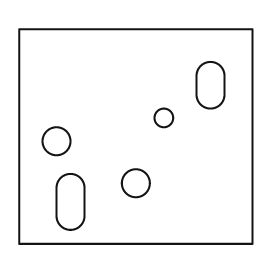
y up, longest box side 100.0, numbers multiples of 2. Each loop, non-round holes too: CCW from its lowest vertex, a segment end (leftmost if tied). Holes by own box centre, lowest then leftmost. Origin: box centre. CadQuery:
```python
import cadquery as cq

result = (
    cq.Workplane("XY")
    .moveTo(-50.0, -46.0)
    .lineTo(50.0, -46.0)
    .lineTo(50.0, 46.0)
    .lineTo(-50.0, 46.0)
    .close()
    .moveTo(-34.0, -34.0)
    .threePointArc((-28.0, -40.0), (-22.0, -34.0))
    .lineTo(-22.0, -22.0)
    .threePointArc((-28.0, -16.0), (-34.0, -22.0))
    .close()
    .moveTo(0.0, -20.0)
    .circle(6.0)
    .moveTo(-34.0, -2.0)
    .circle(6.0)
    .moveTo(12.0, 8.0)
    .circle(4.0)
    .moveTo(26.0, 18.0)
    .threePointArc((32.0, 12.0), (38.0, 18.0))
    .lineTo(38.0, 26.0)
    .threePointArc((32.0, 32.0), (26.0, 26.0))
    .close()
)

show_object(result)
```